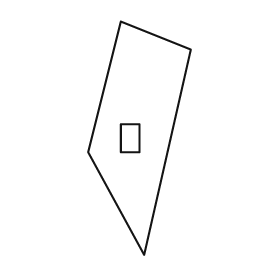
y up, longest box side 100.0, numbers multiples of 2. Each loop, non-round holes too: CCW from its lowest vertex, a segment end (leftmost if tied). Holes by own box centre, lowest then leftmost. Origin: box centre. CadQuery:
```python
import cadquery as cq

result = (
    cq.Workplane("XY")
    .moveTo(2.0, -50.0)
    .lineTo(22.0, 38.0)
    .lineTo(-8.0, 50.0)
    .lineTo(-22.0, -6.0)
    .close()
    .moveTo(-8.0, -6.0)
    .lineTo(0.0, -6.0)
    .lineTo(0.0, 6.0)
    .lineTo(-8.0, 6.0)
    .close()
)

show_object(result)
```